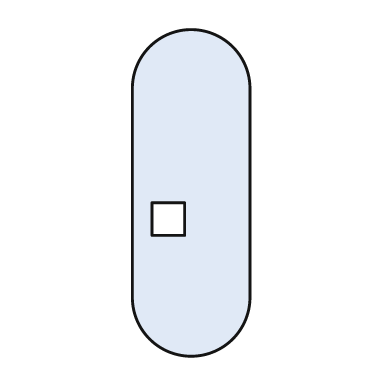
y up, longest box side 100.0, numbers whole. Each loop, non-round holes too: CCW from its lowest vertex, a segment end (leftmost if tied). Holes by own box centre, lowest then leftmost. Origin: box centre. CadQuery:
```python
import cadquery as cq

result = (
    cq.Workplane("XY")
    .moveTo(-18.0, -32.0)
    .threePointArc((0.0, -50.0), (18.0, -32.0))
    .lineTo(18.0, 32.0)
    .threePointArc((0.0, 50.0), (-18.0, 32.0))
    .close()
    .moveTo(-12.0, -13.0)
    .lineTo(-2.0, -13.0)
    .lineTo(-2.0, -3.0)
    .lineTo(-12.0, -3.0)
    .close()
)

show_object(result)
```